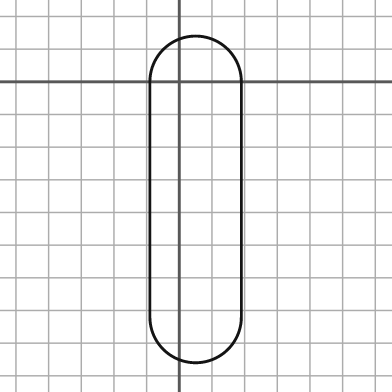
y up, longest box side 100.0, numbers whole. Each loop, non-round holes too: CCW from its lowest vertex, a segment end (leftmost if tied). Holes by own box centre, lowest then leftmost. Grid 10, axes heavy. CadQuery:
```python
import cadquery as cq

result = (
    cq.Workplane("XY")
    .moveTo(-9.0, -72.0)
    .threePointArc((5.0, -86.0), (19.0, -72.0))
    .lineTo(19.0, 0.0)
    .threePointArc((5.0, 14.0), (-9.0, 0.0))
    .close()
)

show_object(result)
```